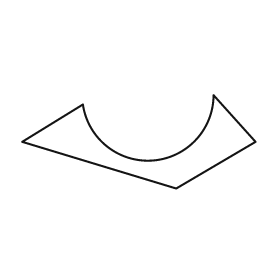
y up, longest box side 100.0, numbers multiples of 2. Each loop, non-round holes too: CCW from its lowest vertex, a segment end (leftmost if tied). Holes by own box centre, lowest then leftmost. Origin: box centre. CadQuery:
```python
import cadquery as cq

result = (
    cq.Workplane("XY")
    .moveTo(16.0, -20.0)
    .lineTo(50.0, 0.0)
    .lineTo(32.0, 20.0)
    .threePointArc((6.0, -8.0), (-24.0, 16.0))
    .lineTo(-50.0, 0.0)
    .close()
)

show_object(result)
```